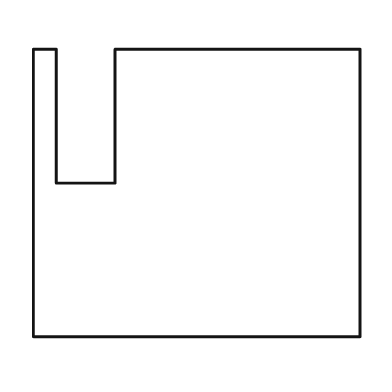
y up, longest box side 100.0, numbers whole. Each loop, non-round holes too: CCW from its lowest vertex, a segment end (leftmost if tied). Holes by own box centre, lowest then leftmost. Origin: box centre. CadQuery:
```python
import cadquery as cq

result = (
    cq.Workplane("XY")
    .moveTo(-50.0, -44.0)
    .lineTo(50.0, -44.0)
    .lineTo(50.0, 44.0)
    .lineTo(-25.0, 44.0)
    .lineTo(-25.0, 3.0)
    .lineTo(-43.0, 3.0)
    .lineTo(-43.0, 44.0)
    .lineTo(-50.0, 44.0)
    .close()
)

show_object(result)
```